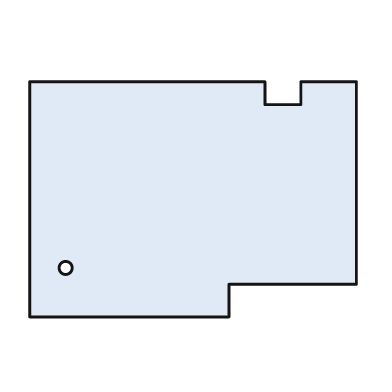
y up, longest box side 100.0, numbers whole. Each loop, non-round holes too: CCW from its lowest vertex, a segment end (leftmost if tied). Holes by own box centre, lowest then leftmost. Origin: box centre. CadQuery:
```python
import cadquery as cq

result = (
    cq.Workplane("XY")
    .moveTo(-50.0, -36.0)
    .lineTo(11.0, -36.0)
    .lineTo(11.0, -26.0)
    .lineTo(50.0, -26.0)
    .lineTo(50.0, 36.0)
    .lineTo(33.0, 36.0)
    .lineTo(33.0, 29.0)
    .lineTo(22.0, 29.0)
    .lineTo(22.0, 36.0)
    .lineTo(-50.0, 36.0)
    .close()
    .moveTo(-39.0, -21.0)
    .circle(2.0)
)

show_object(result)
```